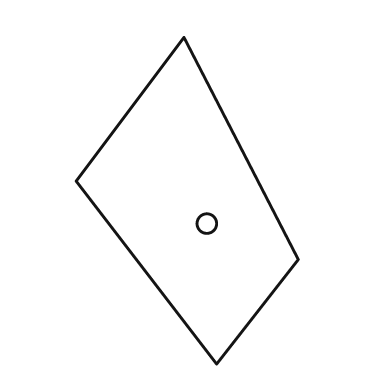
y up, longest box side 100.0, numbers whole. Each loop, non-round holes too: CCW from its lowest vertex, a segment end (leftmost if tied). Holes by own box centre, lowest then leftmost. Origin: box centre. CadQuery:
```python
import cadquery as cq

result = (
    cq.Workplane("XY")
    .moveTo(9.0, -50.0)
    .lineTo(34.0, -18.0)
    .lineTo(-1.0, 50.0)
    .lineTo(-34.0, 6.0)
    .close()
    .moveTo(6.0, -7.0)
    .circle(3.0)
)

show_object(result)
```